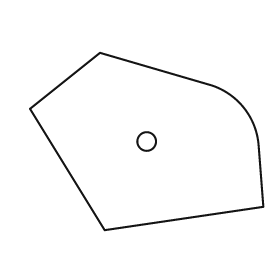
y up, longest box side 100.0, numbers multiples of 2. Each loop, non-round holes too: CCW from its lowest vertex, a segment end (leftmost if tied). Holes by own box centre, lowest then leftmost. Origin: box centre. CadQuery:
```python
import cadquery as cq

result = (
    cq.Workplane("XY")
    .moveTo(-18.0, -38.0)
    .lineTo(50.0, -28.0)
    .lineTo(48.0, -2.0)
    .threePointArc((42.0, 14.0), (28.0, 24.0))
    .lineTo(-20.0, 38.0)
    .lineTo(-50.0, 14.0)
    .close()
    .moveTo(0.0, 0.0)
    .circle(4.0)
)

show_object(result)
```